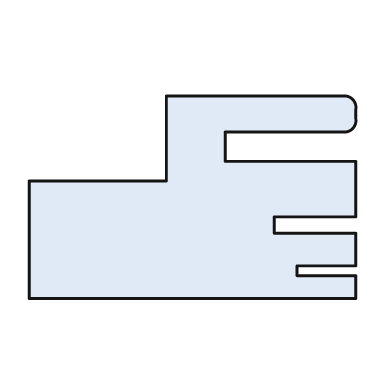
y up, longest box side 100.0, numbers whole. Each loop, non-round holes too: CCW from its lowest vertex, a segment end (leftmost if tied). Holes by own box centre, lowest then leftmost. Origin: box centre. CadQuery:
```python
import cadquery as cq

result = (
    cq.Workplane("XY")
    .moveTo(-50.0, -31.0)
    .lineTo(50.0, -31.0)
    .lineTo(50.0, -24.0)
    .lineTo(32.0, -24.0)
    .lineTo(32.0, -21.0)
    .lineTo(50.0, -21.0)
    .lineTo(50.0, -11.0)
    .lineTo(25.0, -11.0)
    .lineTo(25.0, -6.0)
    .lineTo(50.0, -6.0)
    .lineTo(50.0, 11.0)
    .lineTo(10.0, 11.0)
    .lineTo(10.0, 20.0)
    .lineTo(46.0, 20.0)
    .threePointArc((49.0, 21.0), (50.0, 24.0))
    .lineTo(50.0, 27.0)
    .threePointArc((49.0, 30.0), (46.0, 31.0))
    .lineTo(-8.0, 31.0)
    .lineTo(-8.0, 5.0)
    .lineTo(-50.0, 5.0)
    .close()
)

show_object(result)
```